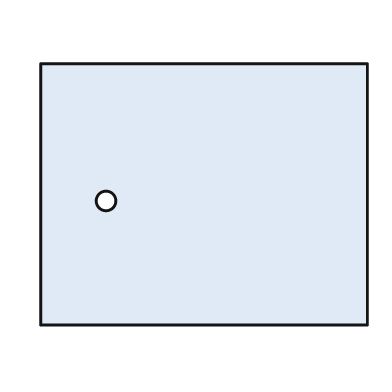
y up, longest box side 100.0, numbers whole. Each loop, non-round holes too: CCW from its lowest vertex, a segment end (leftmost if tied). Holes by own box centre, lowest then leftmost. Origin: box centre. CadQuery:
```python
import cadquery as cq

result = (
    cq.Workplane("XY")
    .moveTo(-50.0, -40.0)
    .lineTo(50.0, -40.0)
    .lineTo(50.0, 40.0)
    .lineTo(-50.0, 40.0)
    .close()
    .moveTo(-30.0, -2.0)
    .circle(3.0)
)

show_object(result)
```